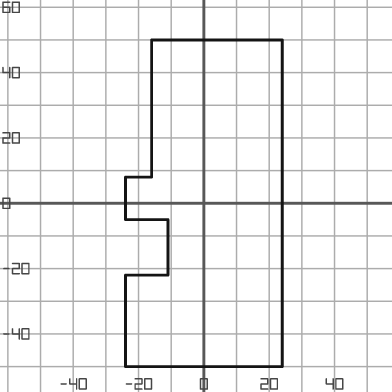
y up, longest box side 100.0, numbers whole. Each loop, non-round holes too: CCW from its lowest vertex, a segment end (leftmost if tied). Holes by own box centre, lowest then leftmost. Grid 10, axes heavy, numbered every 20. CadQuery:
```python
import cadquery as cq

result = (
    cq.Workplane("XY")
    .moveTo(-24.0, -50.0)
    .lineTo(24.0, -50.0)
    .lineTo(24.0, 50.0)
    .lineTo(-16.0, 50.0)
    .lineTo(-16.0, 8.0)
    .lineTo(-24.0, 8.0)
    .lineTo(-24.0, -5.0)
    .lineTo(-11.0, -5.0)
    .lineTo(-11.0, -22.0)
    .lineTo(-24.0, -22.0)
    .close()
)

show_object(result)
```